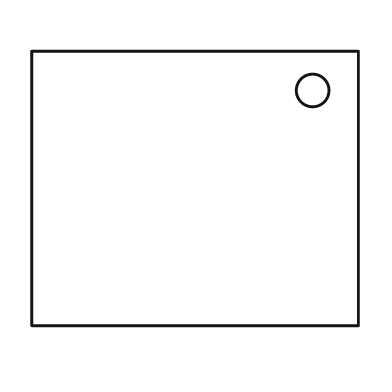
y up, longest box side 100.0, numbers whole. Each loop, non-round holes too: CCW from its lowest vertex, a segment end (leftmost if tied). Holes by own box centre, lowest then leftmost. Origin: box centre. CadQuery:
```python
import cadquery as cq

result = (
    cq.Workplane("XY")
    .moveTo(-50.0, -42.0)
    .lineTo(50.0, -42.0)
    .lineTo(50.0, 42.0)
    .lineTo(-50.0, 42.0)
    .close()
    .moveTo(36.0, 30.0)
    .circle(5.0)
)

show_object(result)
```